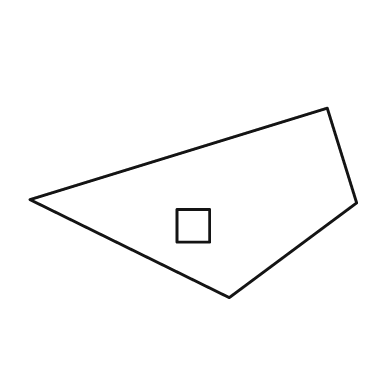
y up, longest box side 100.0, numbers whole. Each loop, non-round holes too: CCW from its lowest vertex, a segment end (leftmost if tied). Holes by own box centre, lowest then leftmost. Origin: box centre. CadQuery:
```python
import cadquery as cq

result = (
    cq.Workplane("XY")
    .moveTo(11.0, -29.0)
    .lineTo(50.0, 0.0)
    .lineTo(41.0, 29.0)
    .lineTo(-50.0, 1.0)
    .close()
    .moveTo(-5.0, -12.0)
    .lineTo(5.0, -12.0)
    .lineTo(5.0, -2.0)
    .lineTo(-5.0, -2.0)
    .close()
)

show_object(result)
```